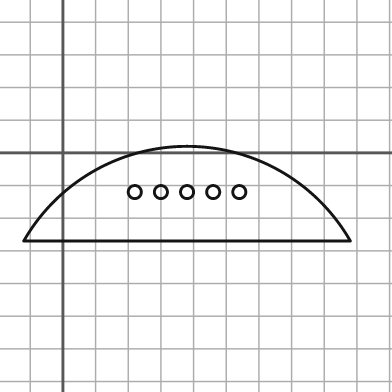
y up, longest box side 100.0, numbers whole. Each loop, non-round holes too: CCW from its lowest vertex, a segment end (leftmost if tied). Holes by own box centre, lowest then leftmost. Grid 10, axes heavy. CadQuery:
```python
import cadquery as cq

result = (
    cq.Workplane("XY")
    .moveTo(-12.0, -27.0)
    .lineTo(88.0, -27.0)
    .threePointArc((38.0, 2.0), (-12.0, -27.0))
    .close()
    .moveTo(22.0, -12.0)
    .circle(2.0)
    .moveTo(30.0, -12.0)
    .circle(2.0)
    .moveTo(38.0, -12.0)
    .circle(2.0)
    .moveTo(46.0, -12.0)
    .circle(2.0)
    .moveTo(54.0, -12.0)
    .circle(2.0)
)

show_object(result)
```